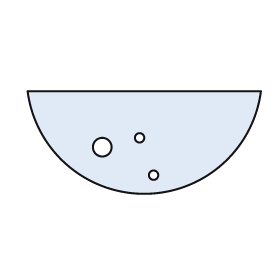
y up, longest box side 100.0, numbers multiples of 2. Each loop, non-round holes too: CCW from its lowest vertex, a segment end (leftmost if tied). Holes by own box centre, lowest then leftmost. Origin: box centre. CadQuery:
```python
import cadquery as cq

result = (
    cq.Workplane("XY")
    .moveTo(-50.0, 22.0)
    .threePointArc((0.0, -22.0), (50.0, 22.0))
    .close()
    .moveTo(4.0, -14.0)
    .circle(2.0)
    .moveTo(-18.0, -2.0)
    .circle(4.0)
    .moveTo(-2.0, 2.0)
    .circle(2.0)
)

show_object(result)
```